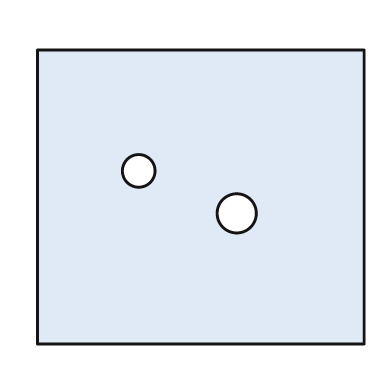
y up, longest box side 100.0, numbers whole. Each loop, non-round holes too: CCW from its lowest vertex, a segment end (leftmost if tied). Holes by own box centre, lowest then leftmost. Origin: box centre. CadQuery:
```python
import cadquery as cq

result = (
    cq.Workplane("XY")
    .moveTo(-50.0, -45.0)
    .lineTo(50.0, -45.0)
    .lineTo(50.0, 45.0)
    .lineTo(-50.0, 45.0)
    .close()
    .moveTo(11.0, -5.0)
    .circle(6.0)
    .moveTo(-19.0, 8.0)
    .circle(5.0)
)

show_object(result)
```